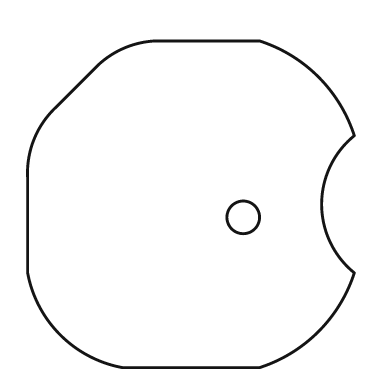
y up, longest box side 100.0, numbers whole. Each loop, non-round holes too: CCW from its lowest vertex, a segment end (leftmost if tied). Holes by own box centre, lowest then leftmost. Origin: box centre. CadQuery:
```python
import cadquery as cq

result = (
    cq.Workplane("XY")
    .moveTo(-21.0, -50.0)
    .lineTo(21.0, -50.0)
    .threePointArc((39.0, -39.0), (50.0, -21.0))
    .threePointArc((40.0, 0.0), (50.0, 21.0))
    .threePointArc((39.0, 39.0), (21.0, 50.0))
    .lineTo(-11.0, 50.0)
    .threePointArc((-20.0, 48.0), (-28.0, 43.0))
    .lineTo(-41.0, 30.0)
    .threePointArc((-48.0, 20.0), (-50.0, 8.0))
    .lineTo(-50.0, -21.0)
    .threePointArc((-40.0, -40.0), (-21.0, -50.0))
    .close()
    .moveTo(16.0, -4.0)
    .circle(5.0)
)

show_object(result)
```